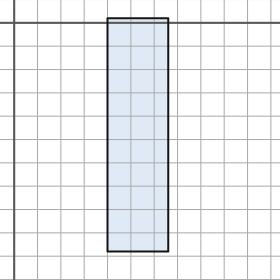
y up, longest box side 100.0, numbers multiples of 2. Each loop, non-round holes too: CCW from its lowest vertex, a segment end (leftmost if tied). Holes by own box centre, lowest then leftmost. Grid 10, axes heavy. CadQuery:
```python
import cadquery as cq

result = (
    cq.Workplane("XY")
    .moveTo(40.0, -98.0)
    .lineTo(66.0, -98.0)
    .lineTo(66.0, 2.0)
    .lineTo(40.0, 2.0)
    .close()
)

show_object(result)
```